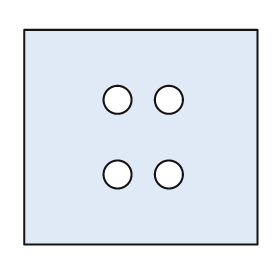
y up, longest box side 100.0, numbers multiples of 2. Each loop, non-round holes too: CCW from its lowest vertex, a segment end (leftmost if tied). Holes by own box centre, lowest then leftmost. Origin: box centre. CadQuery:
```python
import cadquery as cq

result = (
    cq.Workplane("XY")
    .moveTo(-50.0, -46.0)
    .lineTo(50.0, -46.0)
    .lineTo(50.0, 46.0)
    .lineTo(-50.0, 46.0)
    .close()
    .moveTo(-10.0, -16.0)
    .circle(6.0)
    .moveTo(12.0, -16.0)
    .circle(6.0)
    .moveTo(-10.0, 16.0)
    .circle(6.0)
    .moveTo(12.0, 16.0)
    .circle(6.0)
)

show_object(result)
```